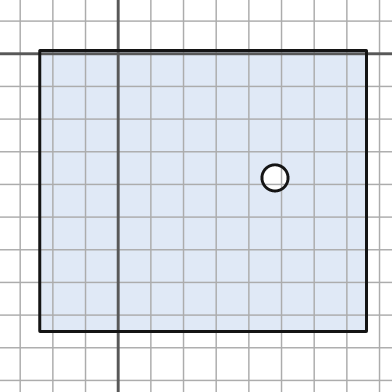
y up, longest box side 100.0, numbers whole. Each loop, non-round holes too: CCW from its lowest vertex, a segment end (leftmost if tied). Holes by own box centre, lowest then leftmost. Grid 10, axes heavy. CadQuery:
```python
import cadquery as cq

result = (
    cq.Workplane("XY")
    .moveTo(-24.0, -85.0)
    .lineTo(76.0, -85.0)
    .lineTo(76.0, 1.0)
    .lineTo(-24.0, 1.0)
    .close()
    .moveTo(48.0, -38.0)
    .circle(4.0)
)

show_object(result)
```